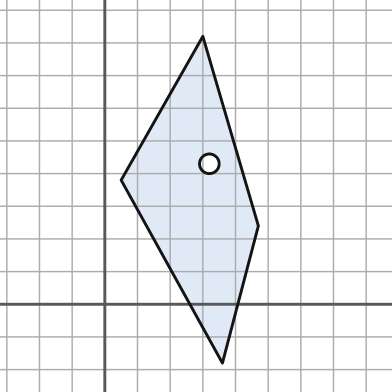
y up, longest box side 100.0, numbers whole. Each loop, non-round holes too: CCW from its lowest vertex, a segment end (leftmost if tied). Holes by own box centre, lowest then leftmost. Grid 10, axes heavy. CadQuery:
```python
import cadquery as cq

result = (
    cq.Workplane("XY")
    .moveTo(36.0, -18.0)
    .lineTo(47.0, 24.0)
    .lineTo(30.0, 82.0)
    .lineTo(5.0, 38.0)
    .close()
    .moveTo(32.0, 43.0)
    .circle(3.0)
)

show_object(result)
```